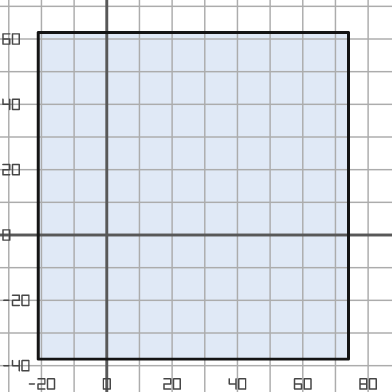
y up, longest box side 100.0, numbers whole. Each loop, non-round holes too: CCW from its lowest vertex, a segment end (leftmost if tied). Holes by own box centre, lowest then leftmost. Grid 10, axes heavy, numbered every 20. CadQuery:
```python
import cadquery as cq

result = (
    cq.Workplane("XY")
    .moveTo(-21.0, -38.0)
    .lineTo(74.0, -38.0)
    .lineTo(74.0, 62.0)
    .lineTo(-21.0, 62.0)
    .close()
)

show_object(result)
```